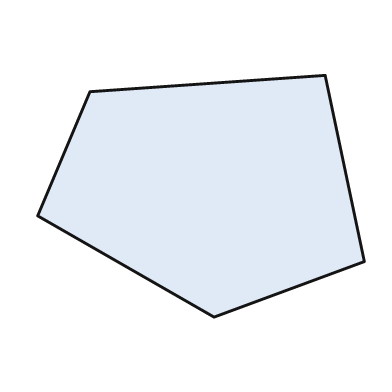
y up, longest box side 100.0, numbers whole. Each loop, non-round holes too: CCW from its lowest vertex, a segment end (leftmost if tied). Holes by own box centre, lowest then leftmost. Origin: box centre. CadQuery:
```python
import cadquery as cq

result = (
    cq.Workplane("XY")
    .moveTo(4.0, -37.0)
    .lineTo(50.0, -20.0)
    .lineTo(38.0, 37.0)
    .lineTo(-34.0, 32.0)
    .lineTo(-50.0, -6.0)
    .close()
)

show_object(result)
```